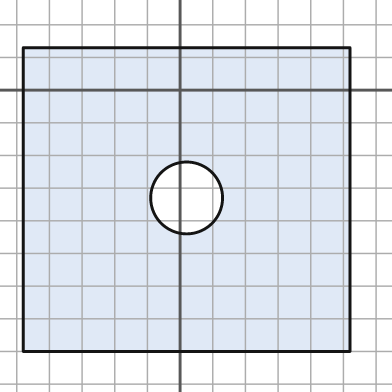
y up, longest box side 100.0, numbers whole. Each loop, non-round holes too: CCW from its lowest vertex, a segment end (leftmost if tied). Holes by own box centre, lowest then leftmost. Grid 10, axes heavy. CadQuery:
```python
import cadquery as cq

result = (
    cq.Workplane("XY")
    .moveTo(-48.0, -80.0)
    .lineTo(52.0, -80.0)
    .lineTo(52.0, 13.0)
    .lineTo(-48.0, 13.0)
    .close()
    .moveTo(2.0, -33.0)
    .circle(11.0)
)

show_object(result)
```